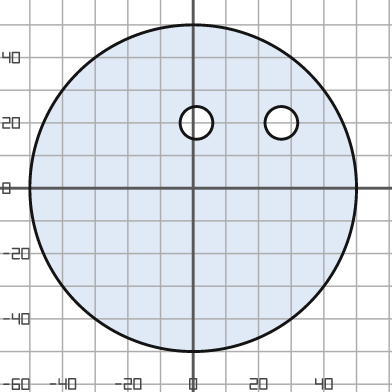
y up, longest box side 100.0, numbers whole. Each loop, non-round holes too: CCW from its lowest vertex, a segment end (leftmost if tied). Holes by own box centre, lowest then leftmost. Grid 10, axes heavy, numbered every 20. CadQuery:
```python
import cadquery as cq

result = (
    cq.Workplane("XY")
    .moveTo(0.0, 0.0)
    .circle(50.0)
    .moveTo(1.0, 20.0)
    .circle(5.0)
    .moveTo(27.0, 20.0)
    .circle(5.0)
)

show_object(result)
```